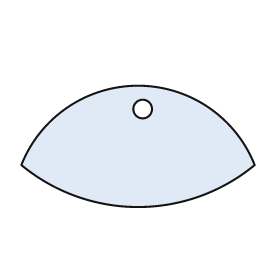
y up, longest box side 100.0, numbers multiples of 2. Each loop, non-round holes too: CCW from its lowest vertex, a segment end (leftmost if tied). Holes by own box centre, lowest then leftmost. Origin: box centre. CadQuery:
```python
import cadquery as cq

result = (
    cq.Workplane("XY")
    .moveTo(-50.0, -8.0)
    .threePointArc((0.0, -26.0), (50.0, -8.0))
    .threePointArc((0.0, 26.0), (-50.0, -8.0))
    .close()
    .moveTo(2.0, 16.0)
    .circle(4.0)
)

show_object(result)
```